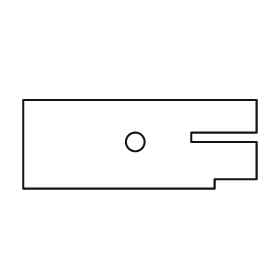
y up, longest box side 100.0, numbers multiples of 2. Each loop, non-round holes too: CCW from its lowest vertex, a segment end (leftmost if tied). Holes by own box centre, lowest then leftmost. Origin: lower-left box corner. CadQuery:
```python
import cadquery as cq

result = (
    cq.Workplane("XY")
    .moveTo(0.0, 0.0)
    .lineTo(82.0, 0.0)
    .lineTo(82.0, 4.0)
    .lineTo(100.0, 4.0)
    .lineTo(100.0, 20.0)
    .lineTo(72.0, 20.0)
    .lineTo(72.0, 24.0)
    .lineTo(100.0, 24.0)
    .lineTo(100.0, 38.0)
    .lineTo(0.0, 38.0)
    .close()
    .moveTo(48.0, 20.0)
    .circle(4.0)
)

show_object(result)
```